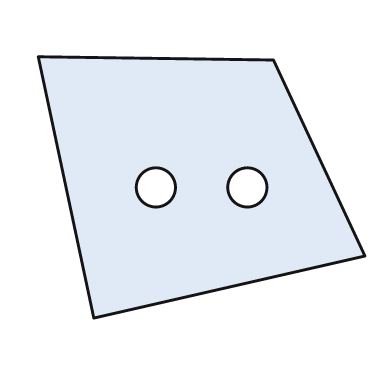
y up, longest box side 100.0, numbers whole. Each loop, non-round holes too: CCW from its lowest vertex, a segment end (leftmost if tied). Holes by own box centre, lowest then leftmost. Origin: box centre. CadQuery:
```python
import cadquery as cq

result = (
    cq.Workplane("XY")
    .moveTo(-33.0, -40.0)
    .lineTo(50.0, -21.0)
    .lineTo(22.0, 39.0)
    .lineTo(-50.0, 40.0)
    .close()
    .moveTo(-14.0, 0.0)
    .circle(6.0)
    .moveTo(14.0, 0.0)
    .circle(6.0)
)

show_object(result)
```